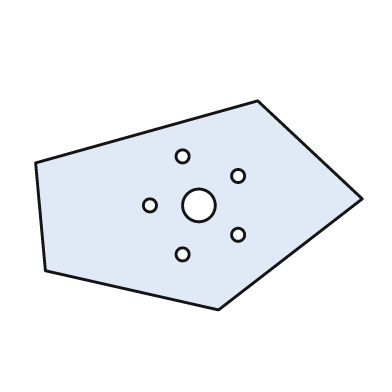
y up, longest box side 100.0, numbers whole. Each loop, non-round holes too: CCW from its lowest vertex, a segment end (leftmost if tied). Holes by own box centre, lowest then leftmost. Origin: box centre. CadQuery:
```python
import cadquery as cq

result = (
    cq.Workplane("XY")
    .moveTo(6.0, -32.0)
    .lineTo(50.0, 2.0)
    .lineTo(18.0, 32.0)
    .lineTo(-50.0, 13.0)
    .lineTo(-47.0, -20.0)
    .close()
    .moveTo(-5.0, -15.0)
    .circle(2.0)
    .moveTo(12.0, -9.0)
    .circle(2.0)
    .moveTo(-15.0, 0.0)
    .circle(2.0)
    .moveTo(0.0, 0.0)
    .circle(5.0)
    .moveTo(12.0, 9.0)
    .circle(2.0)
    .moveTo(-5.0, 15.0)
    .circle(2.0)
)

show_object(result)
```